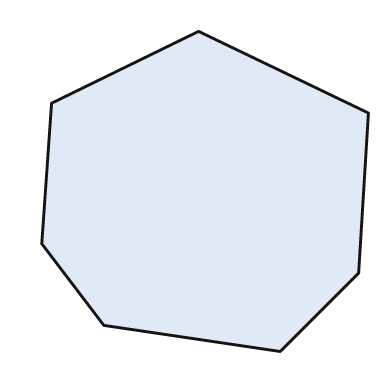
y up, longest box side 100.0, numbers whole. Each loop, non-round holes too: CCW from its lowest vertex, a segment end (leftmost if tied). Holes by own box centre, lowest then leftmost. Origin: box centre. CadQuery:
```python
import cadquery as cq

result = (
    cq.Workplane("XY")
    .moveTo(23.0, -49.0)
    .lineTo(47.0, -25.0)
    .lineTo(50.0, 24.0)
    .lineTo(-2.0, 49.0)
    .lineTo(-47.0, 27.0)
    .lineTo(-50.0, -16.0)
    .lineTo(-31.0, -41.0)
    .close()
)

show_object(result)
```